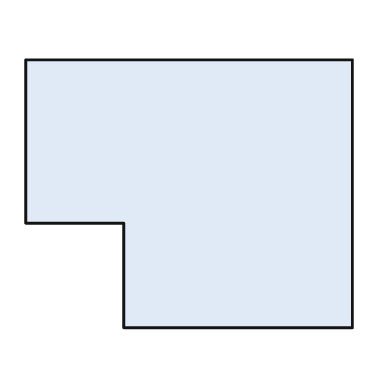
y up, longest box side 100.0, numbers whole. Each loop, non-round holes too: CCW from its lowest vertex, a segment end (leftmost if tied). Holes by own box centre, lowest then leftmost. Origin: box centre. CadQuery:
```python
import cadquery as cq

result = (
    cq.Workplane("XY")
    .moveTo(-20.0, -41.0)
    .lineTo(50.0, -41.0)
    .lineTo(50.0, 41.0)
    .lineTo(-50.0, 41.0)
    .lineTo(-50.0, -9.0)
    .lineTo(-20.0, -9.0)
    .close()
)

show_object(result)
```